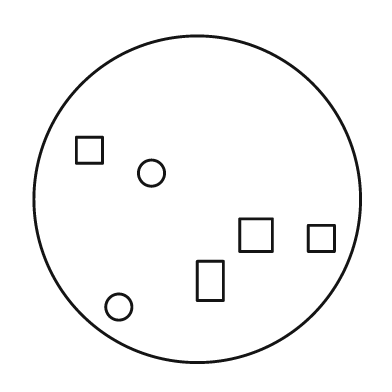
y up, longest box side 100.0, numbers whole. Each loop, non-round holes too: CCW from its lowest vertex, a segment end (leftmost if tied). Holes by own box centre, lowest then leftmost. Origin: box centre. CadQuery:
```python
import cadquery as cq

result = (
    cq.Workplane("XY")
    .moveTo(0.0, 0.0)
    .circle(50.0)
    .moveTo(-24.0, -33.0)
    .circle(4.0)
    .moveTo(0.0, -31.0)
    .lineTo(8.0, -31.0)
    .lineTo(8.0, -19.0)
    .lineTo(0.0, -19.0)
    .close()
    .moveTo(34.0, -16.0)
    .lineTo(42.0, -16.0)
    .lineTo(42.0, -8.0)
    .lineTo(34.0, -8.0)
    .close()
    .moveTo(13.0, -16.0)
    .lineTo(23.0, -16.0)
    .lineTo(23.0, -6.0)
    .lineTo(13.0, -6.0)
    .close()
    .moveTo(-14.0, 8.0)
    .circle(4.0)
    .moveTo(-37.0, 11.0)
    .lineTo(-29.0, 11.0)
    .lineTo(-29.0, 19.0)
    .lineTo(-37.0, 19.0)
    .close()
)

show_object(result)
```